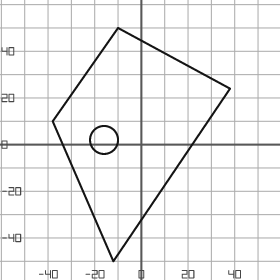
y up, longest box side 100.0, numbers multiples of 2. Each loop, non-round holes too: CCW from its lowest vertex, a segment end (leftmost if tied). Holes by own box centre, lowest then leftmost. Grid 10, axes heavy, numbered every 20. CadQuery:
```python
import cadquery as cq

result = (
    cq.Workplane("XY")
    .moveTo(-12.0, -50.0)
    .lineTo(38.0, 24.0)
    .lineTo(-10.0, 50.0)
    .lineTo(-38.0, 10.0)
    .close()
    .moveTo(-16.0, 2.0)
    .circle(6.0)
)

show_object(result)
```